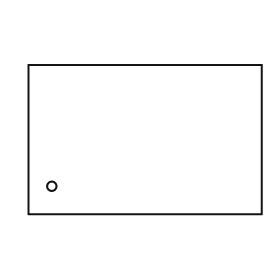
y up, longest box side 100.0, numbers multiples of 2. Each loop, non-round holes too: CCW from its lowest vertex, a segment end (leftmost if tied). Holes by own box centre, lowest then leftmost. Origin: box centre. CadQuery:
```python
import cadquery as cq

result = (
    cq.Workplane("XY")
    .moveTo(-50.0, -32.0)
    .lineTo(50.0, -32.0)
    .lineTo(50.0, 32.0)
    .lineTo(-50.0, 32.0)
    .close()
    .moveTo(-40.0, -20.0)
    .circle(2.0)
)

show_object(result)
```